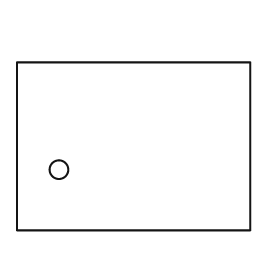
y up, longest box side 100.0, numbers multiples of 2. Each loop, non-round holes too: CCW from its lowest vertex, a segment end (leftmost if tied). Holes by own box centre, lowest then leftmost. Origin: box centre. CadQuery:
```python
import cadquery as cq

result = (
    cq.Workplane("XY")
    .moveTo(-50.0, -36.0)
    .lineTo(50.0, -36.0)
    .lineTo(50.0, 36.0)
    .lineTo(-50.0, 36.0)
    .close()
    .moveTo(-32.0, -10.0)
    .circle(4.0)
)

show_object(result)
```